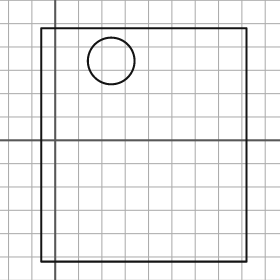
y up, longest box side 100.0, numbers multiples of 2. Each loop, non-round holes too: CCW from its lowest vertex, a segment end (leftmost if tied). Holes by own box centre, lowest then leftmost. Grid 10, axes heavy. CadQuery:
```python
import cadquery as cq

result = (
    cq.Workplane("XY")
    .moveTo(-6.0, -52.0)
    .lineTo(82.0, -52.0)
    .lineTo(82.0, 48.0)
    .lineTo(-6.0, 48.0)
    .close()
    .moveTo(24.0, 34.0)
    .circle(10.0)
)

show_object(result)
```